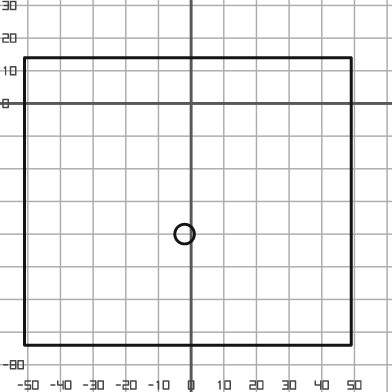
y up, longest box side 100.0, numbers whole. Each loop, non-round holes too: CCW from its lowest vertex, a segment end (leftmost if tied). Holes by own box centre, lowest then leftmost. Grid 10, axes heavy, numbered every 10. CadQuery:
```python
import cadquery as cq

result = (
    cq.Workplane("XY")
    .moveTo(-51.0, -74.0)
    .lineTo(49.0, -74.0)
    .lineTo(49.0, 14.0)
    .lineTo(-51.0, 14.0)
    .close()
    .moveTo(-2.0, -40.0)
    .circle(3.0)
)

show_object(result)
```